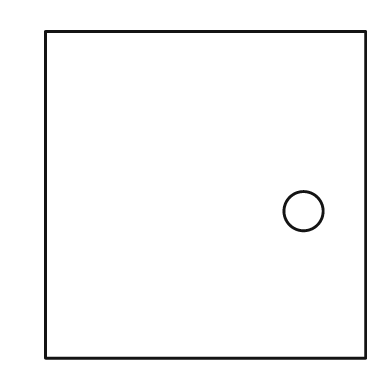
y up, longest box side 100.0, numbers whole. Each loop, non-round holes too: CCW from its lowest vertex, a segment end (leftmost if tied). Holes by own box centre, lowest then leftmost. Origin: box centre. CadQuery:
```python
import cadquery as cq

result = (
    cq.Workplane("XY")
    .moveTo(-49.0, -50.0)
    .lineTo(49.0, -50.0)
    .lineTo(49.0, 50.0)
    .lineTo(-49.0, 50.0)
    .close()
    .moveTo(30.0, -5.0)
    .circle(6.0)
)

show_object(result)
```